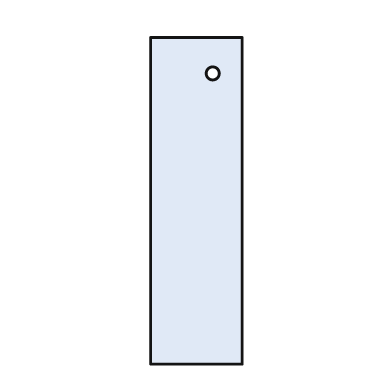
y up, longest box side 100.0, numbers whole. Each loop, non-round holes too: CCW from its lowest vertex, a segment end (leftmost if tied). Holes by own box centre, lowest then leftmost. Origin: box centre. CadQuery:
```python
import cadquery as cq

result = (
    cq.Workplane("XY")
    .moveTo(-14.0, -50.0)
    .lineTo(14.0, -50.0)
    .lineTo(14.0, 50.0)
    .lineTo(-14.0, 50.0)
    .close()
    .moveTo(5.0, 39.0)
    .circle(2.0)
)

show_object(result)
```